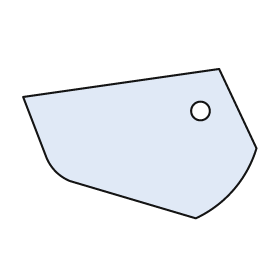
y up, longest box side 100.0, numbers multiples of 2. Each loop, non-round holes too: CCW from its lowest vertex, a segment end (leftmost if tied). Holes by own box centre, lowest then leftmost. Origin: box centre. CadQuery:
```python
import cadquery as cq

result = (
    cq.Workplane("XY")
    .moveTo(24.0, -32.0)
    .threePointArc((40.0, -20.0), (50.0, -2.0))
    .lineTo(34.0, 32.0)
    .lineTo(-50.0, 20.0)
    .lineTo(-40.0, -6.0)
    .threePointArc((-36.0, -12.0), (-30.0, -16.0))
    .close()
    .moveTo(26.0, 14.0)
    .circle(4.0)
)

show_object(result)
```